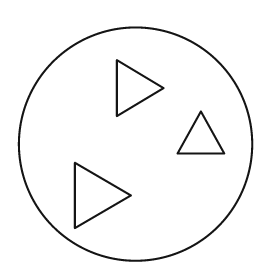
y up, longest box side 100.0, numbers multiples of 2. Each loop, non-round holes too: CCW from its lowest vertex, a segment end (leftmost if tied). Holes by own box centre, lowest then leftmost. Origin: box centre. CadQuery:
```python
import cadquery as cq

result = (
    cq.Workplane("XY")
    .moveTo(0.0, 0.0)
    .circle(50.0)
    .moveTo(-26.0, -36.0)
    .lineTo(-2.0, -22.0)
    .lineTo(-26.0, -8.0)
    .close()
    .moveTo(18.0, -4.0)
    .lineTo(38.0, -4.0)
    .lineTo(28.0, 14.0)
    .close()
    .moveTo(-8.0, 12.0)
    .lineTo(12.0, 24.0)
    .lineTo(-8.0, 36.0)
    .close()
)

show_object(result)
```